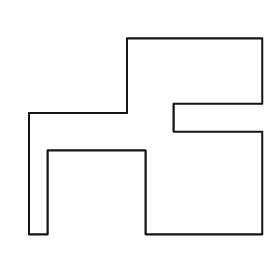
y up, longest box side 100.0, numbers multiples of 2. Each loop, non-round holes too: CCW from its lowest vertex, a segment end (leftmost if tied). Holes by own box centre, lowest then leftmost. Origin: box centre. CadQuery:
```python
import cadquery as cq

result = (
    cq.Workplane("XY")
    .moveTo(-50.0, -42.0)
    .lineTo(-42.0, -42.0)
    .lineTo(-42.0, -6.0)
    .lineTo(0.0, -6.0)
    .lineTo(0.0, -42.0)
    .lineTo(50.0, -42.0)
    .lineTo(50.0, 2.0)
    .lineTo(12.0, 2.0)
    .lineTo(12.0, 14.0)
    .lineTo(50.0, 14.0)
    .lineTo(50.0, 42.0)
    .lineTo(-8.0, 42.0)
    .lineTo(-8.0, 10.0)
    .lineTo(-50.0, 10.0)
    .close()
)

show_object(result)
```